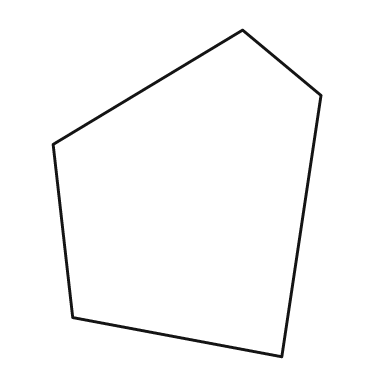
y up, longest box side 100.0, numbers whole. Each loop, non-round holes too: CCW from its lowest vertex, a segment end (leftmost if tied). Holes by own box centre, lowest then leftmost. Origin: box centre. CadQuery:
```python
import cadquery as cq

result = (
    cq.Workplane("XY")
    .moveTo(29.0, -50.0)
    .lineTo(41.0, 30.0)
    .lineTo(17.0, 50.0)
    .lineTo(-41.0, 15.0)
    .lineTo(-35.0, -38.0)
    .close()
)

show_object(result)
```